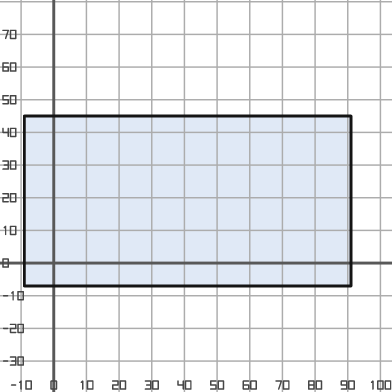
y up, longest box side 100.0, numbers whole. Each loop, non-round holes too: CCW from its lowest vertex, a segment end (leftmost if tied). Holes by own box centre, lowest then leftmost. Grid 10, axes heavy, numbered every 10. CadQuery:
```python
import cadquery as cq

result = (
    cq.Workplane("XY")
    .moveTo(-9.0, -7.0)
    .lineTo(91.0, -7.0)
    .lineTo(91.0, 45.0)
    .lineTo(-9.0, 45.0)
    .close()
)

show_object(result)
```